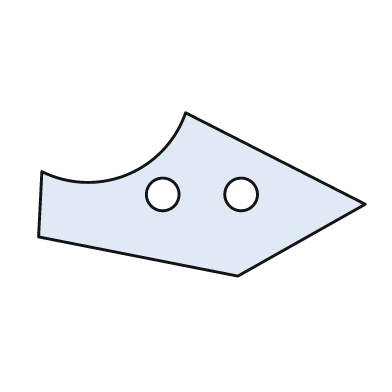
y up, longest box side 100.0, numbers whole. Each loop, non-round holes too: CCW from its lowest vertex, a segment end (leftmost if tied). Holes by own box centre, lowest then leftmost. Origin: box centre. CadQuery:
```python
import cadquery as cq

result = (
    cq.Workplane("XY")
    .moveTo(11.0, -25.0)
    .lineTo(50.0, -3.0)
    .lineTo(-5.0, 25.0)
    .threePointArc((-23.0, 6.0), (-49.0, 7.0))
    .lineTo(-50.0, -13.0)
    .close()
    .moveTo(-12.0, 0.0)
    .circle(5.0)
    .moveTo(12.0, 0.0)
    .circle(5.0)
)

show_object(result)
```